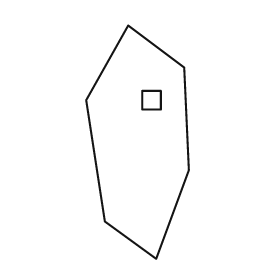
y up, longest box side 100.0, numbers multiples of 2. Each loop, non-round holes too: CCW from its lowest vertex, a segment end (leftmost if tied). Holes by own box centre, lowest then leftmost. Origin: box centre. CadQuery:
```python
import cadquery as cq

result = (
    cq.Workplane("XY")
    .moveTo(8.0, -50.0)
    .lineTo(22.0, -12.0)
    .lineTo(20.0, 32.0)
    .lineTo(-4.0, 50.0)
    .lineTo(-22.0, 18.0)
    .lineTo(-14.0, -34.0)
    .close()
    .moveTo(2.0, 14.0)
    .lineTo(10.0, 14.0)
    .lineTo(10.0, 22.0)
    .lineTo(2.0, 22.0)
    .close()
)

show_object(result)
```